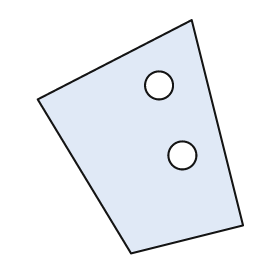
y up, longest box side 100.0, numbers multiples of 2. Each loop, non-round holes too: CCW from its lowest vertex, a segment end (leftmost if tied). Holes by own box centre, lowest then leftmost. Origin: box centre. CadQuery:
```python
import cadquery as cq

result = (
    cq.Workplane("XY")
    .moveTo(-4.0, -50.0)
    .lineTo(44.0, -38.0)
    .lineTo(22.0, 50.0)
    .lineTo(-44.0, 16.0)
    .close()
    .moveTo(18.0, -8.0)
    .circle(6.0)
    .moveTo(8.0, 22.0)
    .circle(6.0)
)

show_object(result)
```